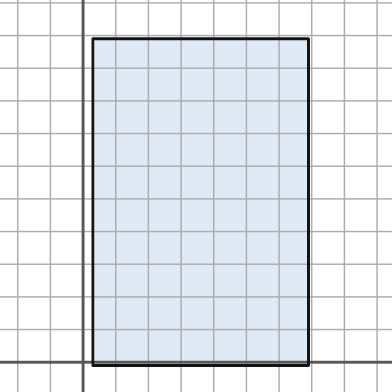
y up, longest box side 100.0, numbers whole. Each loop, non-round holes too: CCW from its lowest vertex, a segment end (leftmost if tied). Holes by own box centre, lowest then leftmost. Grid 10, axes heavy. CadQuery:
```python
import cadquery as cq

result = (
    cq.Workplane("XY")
    .moveTo(3.0, -1.0)
    .lineTo(69.0, -1.0)
    .lineTo(69.0, 99.0)
    .lineTo(3.0, 99.0)
    .close()
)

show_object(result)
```